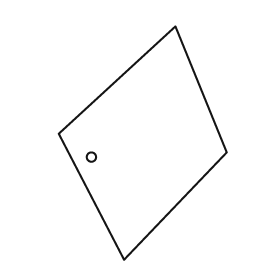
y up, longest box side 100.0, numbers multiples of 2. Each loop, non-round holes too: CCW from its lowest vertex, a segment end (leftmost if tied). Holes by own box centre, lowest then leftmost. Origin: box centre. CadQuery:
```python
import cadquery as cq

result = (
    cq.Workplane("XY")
    .moveTo(-8.0, -50.0)
    .lineTo(36.0, -4.0)
    .lineTo(14.0, 50.0)
    .lineTo(-36.0, 4.0)
    .close()
    .moveTo(-22.0, -6.0)
    .circle(2.0)
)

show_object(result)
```